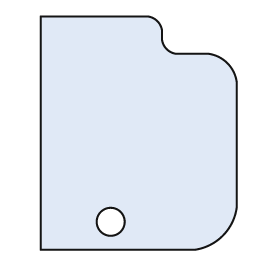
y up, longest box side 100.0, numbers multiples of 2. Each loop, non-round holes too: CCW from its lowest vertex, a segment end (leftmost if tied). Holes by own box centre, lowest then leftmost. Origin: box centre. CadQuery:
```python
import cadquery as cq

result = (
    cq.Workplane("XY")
    .moveTo(-42.0, -50.0)
    .lineTo(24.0, -50.0)
    .threePointArc((36.0, -44.0), (42.0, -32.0))
    .lineTo(42.0, 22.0)
    .threePointArc((38.0, 30.0), (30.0, 34.0))
    .lineTo(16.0, 34.0)
    .threePointArc((12.0, 36.0), (10.0, 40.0))
    .lineTo(10.0, 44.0)
    .threePointArc((8.0, 48.0), (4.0, 50.0))
    .lineTo(-42.0, 50.0)
    .close()
    .moveTo(-12.0, -38.0)
    .circle(6.0)
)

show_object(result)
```